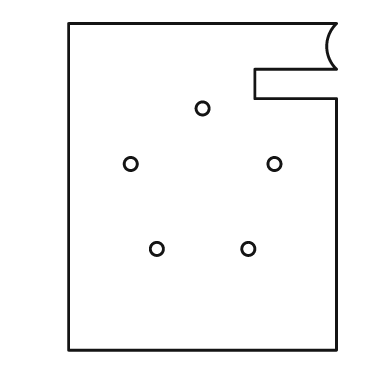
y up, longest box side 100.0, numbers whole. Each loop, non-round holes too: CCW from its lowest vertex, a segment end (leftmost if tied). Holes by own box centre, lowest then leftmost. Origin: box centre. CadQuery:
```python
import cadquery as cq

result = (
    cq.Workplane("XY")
    .moveTo(-41.0, -50.0)
    .lineTo(41.0, -50.0)
    .lineTo(41.0, 27.0)
    .lineTo(16.0, 27.0)
    .lineTo(16.0, 36.0)
    .lineTo(41.0, 36.0)
    .threePointArc((38.0, 43.0), (41.0, 50.0))
    .lineTo(-41.0, 50.0)
    .close()
    .moveTo(-14.0, -19.0)
    .circle(2.0)
    .moveTo(14.0, -19.0)
    .circle(2.0)
    .moveTo(-22.0, 7.0)
    .circle(2.0)
    .moveTo(22.0, 7.0)
    .circle(2.0)
    .moveTo(0.0, 24.0)
    .circle(2.0)
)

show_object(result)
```